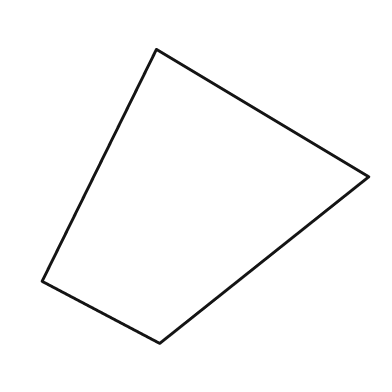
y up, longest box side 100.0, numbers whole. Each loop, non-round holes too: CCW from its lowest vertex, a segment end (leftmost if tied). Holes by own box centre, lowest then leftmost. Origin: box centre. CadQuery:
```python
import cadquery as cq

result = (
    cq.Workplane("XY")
    .moveTo(-14.0, -45.0)
    .lineTo(50.0, 6.0)
    .lineTo(-15.0, 45.0)
    .lineTo(-50.0, -26.0)
    .close()
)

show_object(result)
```